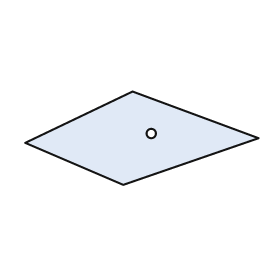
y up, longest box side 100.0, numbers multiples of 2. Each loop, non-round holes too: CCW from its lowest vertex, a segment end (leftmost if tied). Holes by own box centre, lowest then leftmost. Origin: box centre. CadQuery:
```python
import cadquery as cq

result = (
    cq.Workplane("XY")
    .moveTo(-8.0, -20.0)
    .lineTo(50.0, 0.0)
    .lineTo(-4.0, 20.0)
    .lineTo(-50.0, -2.0)
    .close()
    .moveTo(4.0, 2.0)
    .circle(2.0)
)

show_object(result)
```